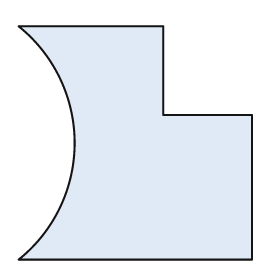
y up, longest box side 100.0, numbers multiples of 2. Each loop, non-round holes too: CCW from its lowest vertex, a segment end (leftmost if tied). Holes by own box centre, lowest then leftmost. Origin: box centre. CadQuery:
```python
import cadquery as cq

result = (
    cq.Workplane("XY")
    .moveTo(-50.0, -50.0)
    .lineTo(50.0, -50.0)
    .lineTo(50.0, 12.0)
    .lineTo(12.0, 12.0)
    .lineTo(12.0, 50.0)
    .lineTo(-50.0, 50.0)
    .threePointArc((-26.0, 0.0), (-50.0, -50.0))
    .close()
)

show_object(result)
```